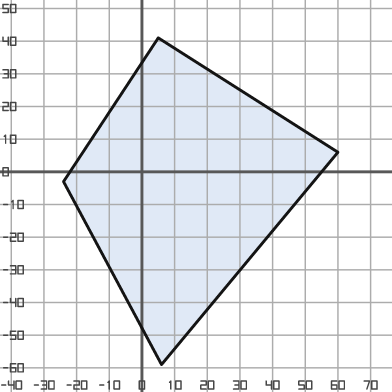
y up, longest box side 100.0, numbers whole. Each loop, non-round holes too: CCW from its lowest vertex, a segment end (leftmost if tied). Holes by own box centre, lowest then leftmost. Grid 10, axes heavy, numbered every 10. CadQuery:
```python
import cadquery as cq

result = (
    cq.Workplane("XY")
    .moveTo(6.0, -59.0)
    .lineTo(60.0, 6.0)
    .lineTo(5.0, 41.0)
    .lineTo(-24.0, -3.0)
    .close()
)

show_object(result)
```